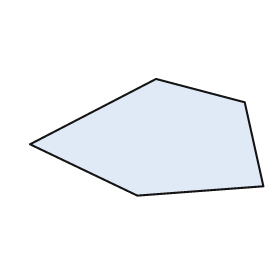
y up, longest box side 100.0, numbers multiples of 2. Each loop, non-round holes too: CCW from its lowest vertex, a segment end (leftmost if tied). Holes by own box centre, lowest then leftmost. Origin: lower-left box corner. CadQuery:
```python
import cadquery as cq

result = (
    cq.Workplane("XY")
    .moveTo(46.0, 0.0)
    .lineTo(100.0, 4.0)
    .lineTo(92.0, 40.0)
    .lineTo(54.0, 50.0)
    .lineTo(0.0, 22.0)
    .close()
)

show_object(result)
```